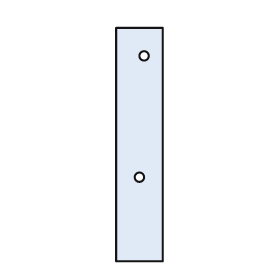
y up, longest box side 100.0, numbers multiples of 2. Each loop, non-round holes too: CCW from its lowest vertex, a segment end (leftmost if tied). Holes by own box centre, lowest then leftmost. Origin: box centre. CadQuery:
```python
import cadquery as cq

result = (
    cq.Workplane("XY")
    .moveTo(-10.0, -50.0)
    .lineTo(10.0, -50.0)
    .lineTo(10.0, 50.0)
    .lineTo(-10.0, 50.0)
    .close()
    .moveTo(0.0, -14.0)
    .circle(2.0)
    .moveTo(2.0, 38.0)
    .circle(2.0)
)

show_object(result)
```